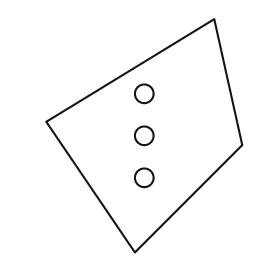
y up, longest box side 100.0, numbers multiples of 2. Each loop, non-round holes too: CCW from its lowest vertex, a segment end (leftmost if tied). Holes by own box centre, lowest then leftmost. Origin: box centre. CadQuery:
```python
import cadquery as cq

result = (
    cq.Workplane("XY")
    .moveTo(-4.0, -50.0)
    .lineTo(42.0, -4.0)
    .lineTo(30.0, 50.0)
    .lineTo(-42.0, 6.0)
    .close()
    .moveTo(0.0, -18.0)
    .circle(4.0)
    .moveTo(0.0, 0.0)
    .circle(4.0)
    .moveTo(0.0, 18.0)
    .circle(4.0)
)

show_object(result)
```